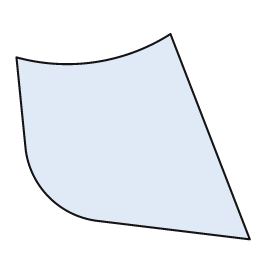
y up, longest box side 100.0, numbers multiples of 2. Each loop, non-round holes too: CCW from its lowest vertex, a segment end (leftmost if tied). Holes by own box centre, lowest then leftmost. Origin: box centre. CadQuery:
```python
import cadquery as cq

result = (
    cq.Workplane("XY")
    .moveTo(50.0, -44.0)
    .lineTo(16.0, 44.0)
    .threePointArc((-16.0, 32.0), (-50.0, 34.0))
    .lineTo(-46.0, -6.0)
    .threePointArc((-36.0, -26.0), (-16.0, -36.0))
    .close()
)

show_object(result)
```